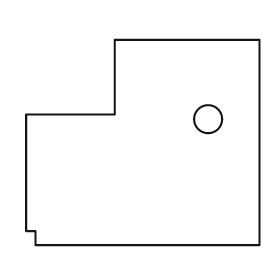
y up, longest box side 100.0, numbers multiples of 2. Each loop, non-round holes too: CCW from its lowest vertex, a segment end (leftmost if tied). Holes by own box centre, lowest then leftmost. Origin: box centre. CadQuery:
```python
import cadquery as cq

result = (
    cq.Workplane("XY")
    .moveTo(-46.0, -44.0)
    .lineTo(50.0, -44.0)
    .lineTo(50.0, 44.0)
    .lineTo(-12.0, 44.0)
    .lineTo(-12.0, 12.0)
    .lineTo(-50.0, 12.0)
    .lineTo(-50.0, -38.0)
    .lineTo(-46.0, -38.0)
    .close()
    .moveTo(28.0, 10.0)
    .circle(6.0)
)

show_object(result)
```